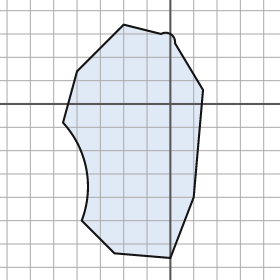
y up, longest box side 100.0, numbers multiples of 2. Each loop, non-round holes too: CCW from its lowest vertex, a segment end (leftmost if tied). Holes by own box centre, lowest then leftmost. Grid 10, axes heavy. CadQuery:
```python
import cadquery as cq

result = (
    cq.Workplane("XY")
    .moveTo(0.0, -66.0)
    .lineTo(10.0, -40.0)
    .lineTo(14.0, 6.0)
    .lineTo(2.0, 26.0)
    .threePointArc((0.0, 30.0), (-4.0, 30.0))
    .lineTo(-20.0, 34.0)
    .lineTo(-40.0, 14.0)
    .lineTo(-46.0, -8.0)
    .threePointArc((-36.0, -28.0), (-38.0, -50.0))
    .lineTo(-24.0, -64.0)
    .close()
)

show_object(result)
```